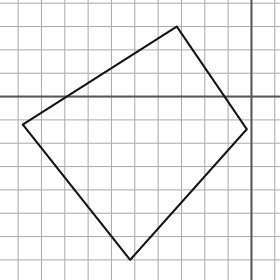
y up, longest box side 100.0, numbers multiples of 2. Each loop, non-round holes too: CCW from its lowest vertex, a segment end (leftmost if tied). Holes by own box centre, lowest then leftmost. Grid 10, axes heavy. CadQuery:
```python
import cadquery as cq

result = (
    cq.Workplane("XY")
    .moveTo(-52.0, -70.0)
    .lineTo(-2.0, -14.0)
    .lineTo(-32.0, 30.0)
    .lineTo(-98.0, -12.0)
    .close()
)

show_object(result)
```